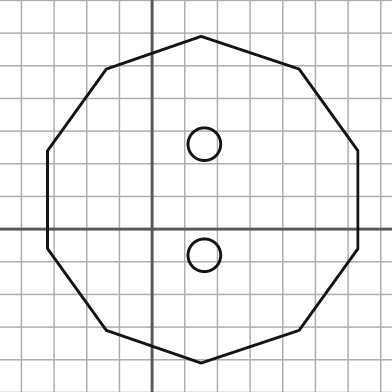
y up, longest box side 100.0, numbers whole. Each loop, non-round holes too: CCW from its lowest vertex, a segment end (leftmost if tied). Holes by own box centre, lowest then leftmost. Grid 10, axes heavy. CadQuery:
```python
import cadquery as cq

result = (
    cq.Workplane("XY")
    .moveTo(15.0, -41.0)
    .lineTo(45.0, -31.0)
    .lineTo(63.0, -6.0)
    .lineTo(63.0, 24.0)
    .lineTo(45.0, 49.0)
    .lineTo(15.0, 59.0)
    .lineTo(-14.0, 49.0)
    .lineTo(-32.0, 24.0)
    .lineTo(-32.0, -6.0)
    .lineTo(-14.0, -31.0)
    .close()
    .moveTo(16.0, -8.0)
    .circle(5.0)
    .moveTo(16.0, 26.0)
    .circle(5.0)
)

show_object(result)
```